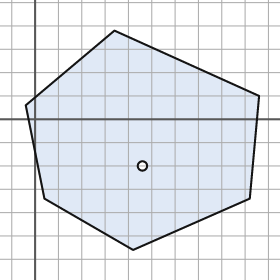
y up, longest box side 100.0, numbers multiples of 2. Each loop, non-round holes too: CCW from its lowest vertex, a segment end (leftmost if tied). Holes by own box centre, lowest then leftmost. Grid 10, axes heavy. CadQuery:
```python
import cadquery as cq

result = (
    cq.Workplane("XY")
    .moveTo(42.0, -56.0)
    .lineTo(92.0, -34.0)
    .lineTo(96.0, 10.0)
    .lineTo(34.0, 38.0)
    .lineTo(-4.0, 6.0)
    .lineTo(4.0, -34.0)
    .close()
    .moveTo(46.0, -20.0)
    .circle(2.0)
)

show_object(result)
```